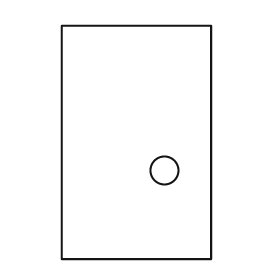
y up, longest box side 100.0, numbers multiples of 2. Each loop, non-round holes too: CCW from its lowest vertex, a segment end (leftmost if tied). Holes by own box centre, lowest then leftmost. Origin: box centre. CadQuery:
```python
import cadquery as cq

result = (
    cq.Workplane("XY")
    .moveTo(-32.0, -50.0)
    .lineTo(32.0, -50.0)
    .lineTo(32.0, 50.0)
    .lineTo(-32.0, 50.0)
    .close()
    .moveTo(12.0, -12.0)
    .circle(6.0)
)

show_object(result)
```